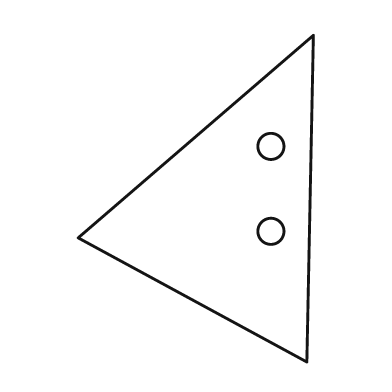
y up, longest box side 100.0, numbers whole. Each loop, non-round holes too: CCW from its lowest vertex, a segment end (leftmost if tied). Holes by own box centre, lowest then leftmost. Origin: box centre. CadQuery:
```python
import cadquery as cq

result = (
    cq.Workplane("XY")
    .moveTo(34.0, -50.0)
    .lineTo(36.0, 50.0)
    .lineTo(-36.0, -12.0)
    .close()
    .moveTo(23.0, -10.0)
    .circle(4.0)
    .moveTo(23.0, 16.0)
    .circle(4.0)
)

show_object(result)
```